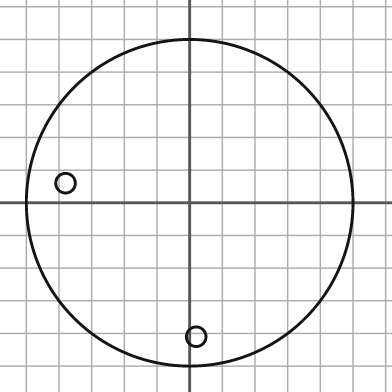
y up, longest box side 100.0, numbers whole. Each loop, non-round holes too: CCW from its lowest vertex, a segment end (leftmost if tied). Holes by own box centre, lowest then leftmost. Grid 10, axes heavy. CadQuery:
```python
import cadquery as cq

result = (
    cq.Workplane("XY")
    .moveTo(0.0, 0.0)
    .circle(50.0)
    .moveTo(2.0, -41.0)
    .circle(3.0)
    .moveTo(-38.0, 6.0)
    .circle(3.0)
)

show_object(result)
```